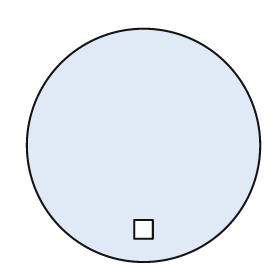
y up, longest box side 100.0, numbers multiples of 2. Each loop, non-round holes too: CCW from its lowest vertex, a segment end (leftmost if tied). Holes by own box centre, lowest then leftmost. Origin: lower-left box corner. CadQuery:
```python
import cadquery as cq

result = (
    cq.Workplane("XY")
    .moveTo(50.0, 50.0)
    .circle(50.0)
    .moveTo(46.0, 10.0)
    .lineTo(54.0, 10.0)
    .lineTo(54.0, 18.0)
    .lineTo(46.0, 18.0)
    .close()
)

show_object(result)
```